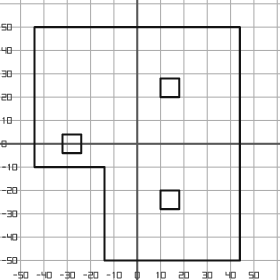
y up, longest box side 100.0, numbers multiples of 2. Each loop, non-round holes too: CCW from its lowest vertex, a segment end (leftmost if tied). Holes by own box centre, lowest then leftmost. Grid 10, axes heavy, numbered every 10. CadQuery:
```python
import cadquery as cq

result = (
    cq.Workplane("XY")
    .moveTo(-14.0, -50.0)
    .lineTo(44.0, -50.0)
    .lineTo(44.0, 50.0)
    .lineTo(-44.0, 50.0)
    .lineTo(-44.0, -10.0)
    .lineTo(-14.0, -10.0)
    .close()
    .moveTo(10.0, -28.0)
    .lineTo(18.0, -28.0)
    .lineTo(18.0, -20.0)
    .lineTo(10.0, -20.0)
    .close()
    .moveTo(-32.0, -4.0)
    .lineTo(-24.0, -4.0)
    .lineTo(-24.0, 4.0)
    .lineTo(-32.0, 4.0)
    .close()
    .moveTo(10.0, 20.0)
    .lineTo(18.0, 20.0)
    .lineTo(18.0, 28.0)
    .lineTo(10.0, 28.0)
    .close()
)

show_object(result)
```